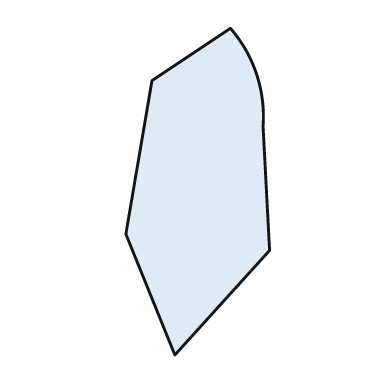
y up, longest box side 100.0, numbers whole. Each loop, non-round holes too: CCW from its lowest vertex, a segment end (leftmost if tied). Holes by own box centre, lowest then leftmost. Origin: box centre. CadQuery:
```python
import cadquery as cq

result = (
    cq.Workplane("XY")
    .moveTo(-7.0, -50.0)
    .lineTo(22.0, -18.0)
    .lineTo(20.0, 20.0)
    .threePointArc((18.0, 36.0), (10.0, 50.0))
    .lineTo(-14.0, 34.0)
    .lineTo(-22.0, -13.0)
    .close()
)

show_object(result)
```